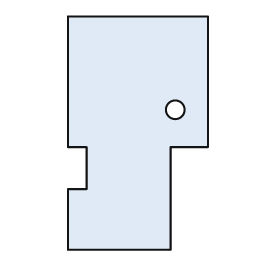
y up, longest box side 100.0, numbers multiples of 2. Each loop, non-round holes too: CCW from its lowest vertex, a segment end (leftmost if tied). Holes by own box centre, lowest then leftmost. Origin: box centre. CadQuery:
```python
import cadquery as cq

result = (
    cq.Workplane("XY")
    .moveTo(-30.0, -50.0)
    .lineTo(14.0, -50.0)
    .lineTo(14.0, -6.0)
    .lineTo(30.0, -6.0)
    .lineTo(30.0, 50.0)
    .lineTo(-30.0, 50.0)
    .lineTo(-30.0, -6.0)
    .lineTo(-22.0, -6.0)
    .lineTo(-22.0, -24.0)
    .lineTo(-30.0, -24.0)
    .close()
    .moveTo(16.0, 10.0)
    .circle(4.0)
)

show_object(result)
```